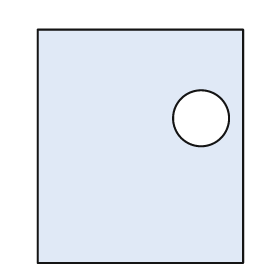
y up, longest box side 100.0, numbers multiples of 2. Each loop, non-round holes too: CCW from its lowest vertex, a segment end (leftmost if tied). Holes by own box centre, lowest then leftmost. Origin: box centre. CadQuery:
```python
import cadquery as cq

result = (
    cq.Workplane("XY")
    .moveTo(-44.0, -50.0)
    .lineTo(44.0, -50.0)
    .lineTo(44.0, 50.0)
    .lineTo(-44.0, 50.0)
    .close()
    .moveTo(26.0, 12.0)
    .circle(12.0)
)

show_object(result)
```